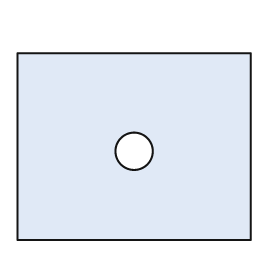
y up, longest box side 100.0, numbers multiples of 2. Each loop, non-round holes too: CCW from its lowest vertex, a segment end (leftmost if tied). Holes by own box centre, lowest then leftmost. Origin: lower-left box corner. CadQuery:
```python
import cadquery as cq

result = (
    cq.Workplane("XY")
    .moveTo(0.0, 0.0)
    .lineTo(100.0, 0.0)
    .lineTo(100.0, 80.0)
    .lineTo(0.0, 80.0)
    .close()
    .moveTo(50.0, 38.0)
    .circle(8.0)
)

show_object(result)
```